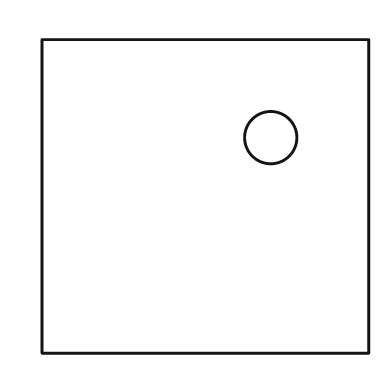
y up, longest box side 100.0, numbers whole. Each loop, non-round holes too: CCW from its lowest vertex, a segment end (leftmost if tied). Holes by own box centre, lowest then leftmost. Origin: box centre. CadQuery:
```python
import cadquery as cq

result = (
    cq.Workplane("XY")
    .moveTo(-50.0, -48.0)
    .lineTo(50.0, -48.0)
    .lineTo(50.0, 48.0)
    .lineTo(-50.0, 48.0)
    .close()
    .moveTo(20.0, 18.0)
    .circle(8.0)
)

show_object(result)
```